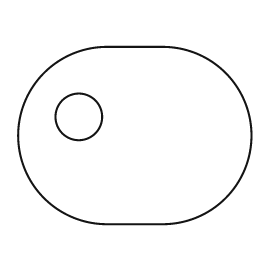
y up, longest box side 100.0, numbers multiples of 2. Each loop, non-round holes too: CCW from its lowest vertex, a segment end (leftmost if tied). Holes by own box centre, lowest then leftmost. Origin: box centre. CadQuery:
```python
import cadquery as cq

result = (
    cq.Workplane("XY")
    .moveTo(-12.0, -38.0)
    .lineTo(12.0, -38.0)
    .threePointArc((50.0, 0.0), (12.0, 38.0))
    .lineTo(-12.0, 38.0)
    .threePointArc((-50.0, 0.0), (-12.0, -38.0))
    .close()
    .moveTo(-24.0, 8.0)
    .circle(10.0)
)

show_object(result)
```